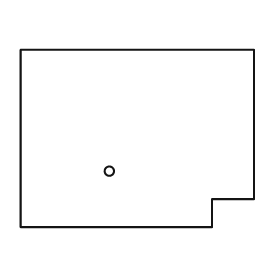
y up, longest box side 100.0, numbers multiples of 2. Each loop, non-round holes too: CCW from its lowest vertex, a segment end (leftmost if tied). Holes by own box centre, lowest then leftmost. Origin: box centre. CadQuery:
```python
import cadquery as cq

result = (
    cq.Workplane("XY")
    .moveTo(-50.0, -38.0)
    .lineTo(32.0, -38.0)
    .lineTo(32.0, -26.0)
    .lineTo(50.0, -26.0)
    .lineTo(50.0, 38.0)
    .lineTo(-50.0, 38.0)
    .close()
    .moveTo(-12.0, -14.0)
    .circle(2.0)
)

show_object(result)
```